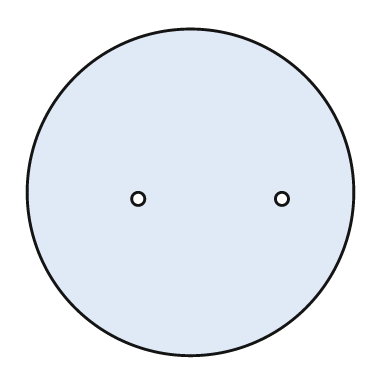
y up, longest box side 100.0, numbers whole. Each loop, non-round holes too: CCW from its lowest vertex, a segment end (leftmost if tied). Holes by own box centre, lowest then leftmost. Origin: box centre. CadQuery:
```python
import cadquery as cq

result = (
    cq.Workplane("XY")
    .moveTo(0.0, 0.0)
    .circle(50.0)
    .moveTo(-16.0, -2.0)
    .circle(2.0)
    .moveTo(28.0, -2.0)
    .circle(2.0)
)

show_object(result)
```